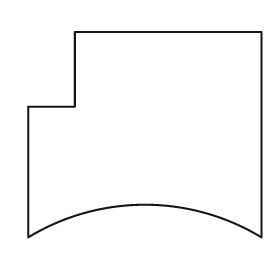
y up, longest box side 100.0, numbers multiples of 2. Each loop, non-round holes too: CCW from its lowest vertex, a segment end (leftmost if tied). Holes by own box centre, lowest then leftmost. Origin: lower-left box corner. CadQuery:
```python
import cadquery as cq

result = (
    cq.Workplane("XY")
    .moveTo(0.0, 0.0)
    .threePointArc((50.0, 14.0), (100.0, 0.0))
    .lineTo(100.0, 88.0)
    .lineTo(20.0, 88.0)
    .lineTo(20.0, 56.0)
    .lineTo(0.0, 56.0)
    .close()
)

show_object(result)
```